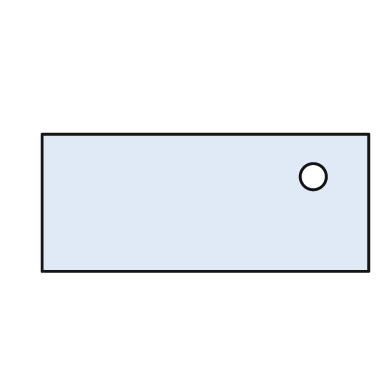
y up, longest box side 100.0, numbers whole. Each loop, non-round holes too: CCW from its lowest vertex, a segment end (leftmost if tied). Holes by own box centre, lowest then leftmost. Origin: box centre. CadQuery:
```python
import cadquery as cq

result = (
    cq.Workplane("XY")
    .moveTo(-50.0, -21.0)
    .lineTo(50.0, -21.0)
    .lineTo(50.0, 21.0)
    .lineTo(-50.0, 21.0)
    .close()
    .moveTo(33.0, 8.0)
    .circle(4.0)
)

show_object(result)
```